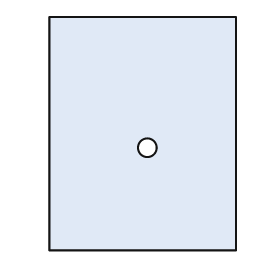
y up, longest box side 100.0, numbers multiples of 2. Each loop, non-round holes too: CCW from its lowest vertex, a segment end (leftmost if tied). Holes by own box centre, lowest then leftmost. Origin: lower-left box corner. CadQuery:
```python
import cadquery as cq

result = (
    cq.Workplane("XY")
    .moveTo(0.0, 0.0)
    .lineTo(80.0, 0.0)
    .lineTo(80.0, 100.0)
    .lineTo(0.0, 100.0)
    .close()
    .moveTo(42.0, 44.0)
    .circle(4.0)
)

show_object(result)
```